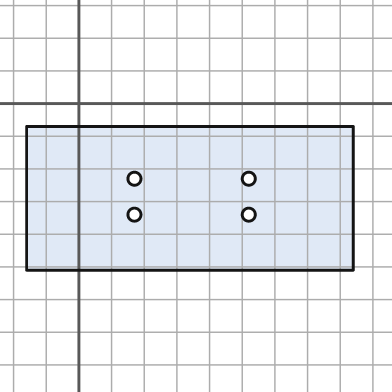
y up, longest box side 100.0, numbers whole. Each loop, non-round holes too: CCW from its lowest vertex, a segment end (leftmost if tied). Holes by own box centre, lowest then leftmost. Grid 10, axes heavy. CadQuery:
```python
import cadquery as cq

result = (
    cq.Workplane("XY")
    .moveTo(-16.0, -51.0)
    .lineTo(84.0, -51.0)
    .lineTo(84.0, -7.0)
    .lineTo(-16.0, -7.0)
    .close()
    .moveTo(17.0, -34.0)
    .circle(2.0)
    .moveTo(52.0, -34.0)
    .circle(2.0)
    .moveTo(17.0, -23.0)
    .circle(2.0)
    .moveTo(52.0, -23.0)
    .circle(2.0)
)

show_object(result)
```